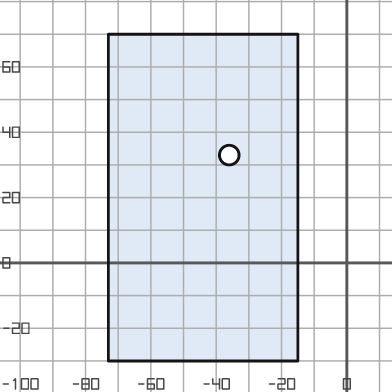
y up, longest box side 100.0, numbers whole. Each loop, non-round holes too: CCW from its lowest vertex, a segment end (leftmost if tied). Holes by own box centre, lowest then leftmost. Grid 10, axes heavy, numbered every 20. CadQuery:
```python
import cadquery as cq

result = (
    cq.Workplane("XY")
    .moveTo(-73.0, -30.0)
    .lineTo(-15.0, -30.0)
    .lineTo(-15.0, 70.0)
    .lineTo(-73.0, 70.0)
    .close()
    .moveTo(-36.0, 33.0)
    .circle(3.0)
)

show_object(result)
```